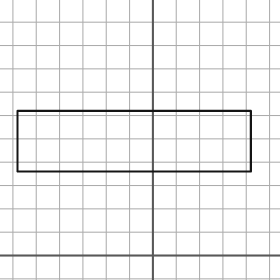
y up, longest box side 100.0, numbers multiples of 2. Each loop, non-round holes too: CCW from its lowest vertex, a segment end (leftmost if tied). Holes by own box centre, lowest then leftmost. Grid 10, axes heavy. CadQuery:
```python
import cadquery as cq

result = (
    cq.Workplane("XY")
    .moveTo(-58.0, 36.0)
    .lineTo(42.0, 36.0)
    .lineTo(42.0, 62.0)
    .lineTo(-58.0, 62.0)
    .close()
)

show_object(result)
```